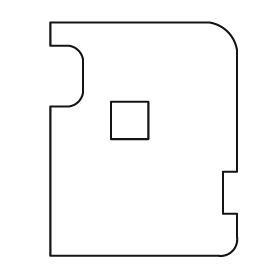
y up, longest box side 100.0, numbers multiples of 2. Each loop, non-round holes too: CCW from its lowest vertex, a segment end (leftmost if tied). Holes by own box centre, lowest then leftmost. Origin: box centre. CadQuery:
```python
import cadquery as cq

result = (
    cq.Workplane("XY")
    .moveTo(-40.0, -50.0)
    .lineTo(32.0, -50.0)
    .threePointArc((38.0, -48.0), (40.0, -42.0))
    .lineTo(40.0, -32.0)
    .lineTo(34.0, -32.0)
    .lineTo(34.0, -14.0)
    .lineTo(40.0, -14.0)
    .lineTo(40.0, 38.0)
    .threePointArc((36.0, 46.0), (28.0, 50.0))
    .lineTo(-40.0, 50.0)
    .lineTo(-40.0, 40.0)
    .lineTo(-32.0, 40.0)
    .threePointArc((-28.0, 38.0), (-26.0, 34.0))
    .lineTo(-26.0, 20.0)
    .threePointArc((-28.0, 16.0), (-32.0, 14.0))
    .lineTo(-40.0, 14.0)
    .close()
    .moveTo(-14.0, 0.0)
    .lineTo(2.0, 0.0)
    .lineTo(2.0, 16.0)
    .lineTo(-14.0, 16.0)
    .close()
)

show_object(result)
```